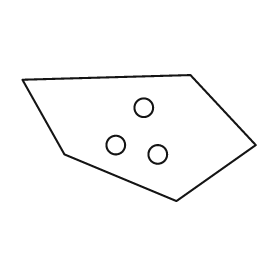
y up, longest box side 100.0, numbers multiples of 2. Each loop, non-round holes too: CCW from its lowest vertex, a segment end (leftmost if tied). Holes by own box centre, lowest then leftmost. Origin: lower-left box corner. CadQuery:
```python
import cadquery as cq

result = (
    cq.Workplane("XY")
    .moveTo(66.0, 0.0)
    .lineTo(100.0, 24.0)
    .lineTo(72.0, 54.0)
    .lineTo(0.0, 52.0)
    .lineTo(18.0, 20.0)
    .close()
    .moveTo(58.0, 20.0)
    .circle(4.0)
    .moveTo(40.0, 24.0)
    .circle(4.0)
    .moveTo(52.0, 40.0)
    .circle(4.0)
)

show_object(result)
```